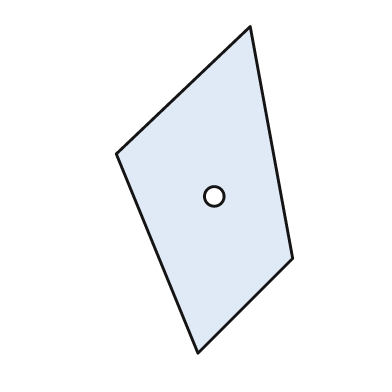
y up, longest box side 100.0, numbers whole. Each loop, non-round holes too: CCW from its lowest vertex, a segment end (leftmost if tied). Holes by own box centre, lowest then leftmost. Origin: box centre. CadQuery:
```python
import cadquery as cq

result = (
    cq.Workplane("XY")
    .moveTo(-2.0, -50.0)
    .lineTo(27.0, -21.0)
    .lineTo(14.0, 50.0)
    .lineTo(-27.0, 11.0)
    .close()
    .moveTo(3.0, -2.0)
    .circle(3.0)
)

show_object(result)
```